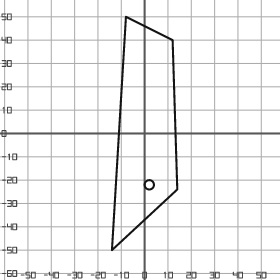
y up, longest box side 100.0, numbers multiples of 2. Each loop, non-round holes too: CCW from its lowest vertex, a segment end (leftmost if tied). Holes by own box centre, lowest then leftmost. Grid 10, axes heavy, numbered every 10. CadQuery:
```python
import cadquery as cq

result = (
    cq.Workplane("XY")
    .moveTo(-14.0, -50.0)
    .lineTo(14.0, -24.0)
    .lineTo(12.0, 40.0)
    .lineTo(-8.0, 50.0)
    .close()
    .moveTo(2.0, -22.0)
    .circle(2.0)
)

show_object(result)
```